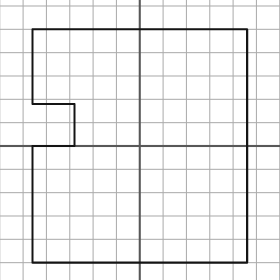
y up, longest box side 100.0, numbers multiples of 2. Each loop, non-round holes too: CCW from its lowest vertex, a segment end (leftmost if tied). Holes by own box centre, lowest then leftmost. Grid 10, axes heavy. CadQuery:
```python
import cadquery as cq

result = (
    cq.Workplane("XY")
    .moveTo(-46.0, -50.0)
    .lineTo(46.0, -50.0)
    .lineTo(46.0, 50.0)
    .lineTo(-46.0, 50.0)
    .lineTo(-46.0, 18.0)
    .lineTo(-28.0, 18.0)
    .lineTo(-28.0, 0.0)
    .lineTo(-46.0, 0.0)
    .close()
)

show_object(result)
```